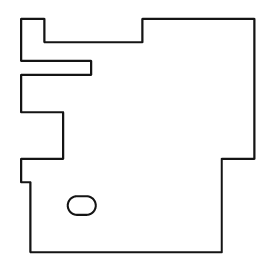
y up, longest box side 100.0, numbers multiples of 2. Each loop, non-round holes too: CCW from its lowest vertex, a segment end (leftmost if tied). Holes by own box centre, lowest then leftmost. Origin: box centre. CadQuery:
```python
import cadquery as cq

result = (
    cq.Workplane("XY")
    .moveTo(-46.0, -50.0)
    .lineTo(36.0, -50.0)
    .lineTo(36.0, -10.0)
    .lineTo(50.0, -10.0)
    .lineTo(50.0, 50.0)
    .lineTo(2.0, 50.0)
    .lineTo(2.0, 40.0)
    .lineTo(-40.0, 40.0)
    .lineTo(-40.0, 50.0)
    .lineTo(-50.0, 50.0)
    .lineTo(-50.0, 32.0)
    .lineTo(-20.0, 32.0)
    .lineTo(-20.0, 26.0)
    .lineTo(-50.0, 26.0)
    .lineTo(-50.0, 10.0)
    .lineTo(-32.0, 10.0)
    .lineTo(-32.0, -10.0)
    .lineTo(-50.0, -10.0)
    .lineTo(-50.0, -20.0)
    .lineTo(-46.0, -20.0)
    .close()
    .moveTo(-26.0, -34.0)
    .lineTo(-22.0, -34.0)
    .threePointArc((-18.0, -30.0), (-22.0, -26.0))
    .lineTo(-26.0, -26.0)
    .threePointArc((-30.0, -30.0), (-26.0, -34.0))
    .close()
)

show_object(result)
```